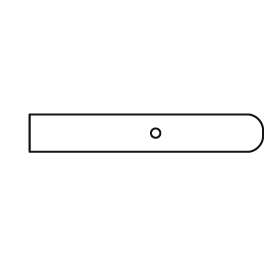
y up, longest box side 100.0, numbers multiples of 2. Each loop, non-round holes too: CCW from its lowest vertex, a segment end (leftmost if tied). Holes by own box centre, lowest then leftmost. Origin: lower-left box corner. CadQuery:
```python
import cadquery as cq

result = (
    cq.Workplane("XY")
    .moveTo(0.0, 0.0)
    .lineTo(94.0, 0.0)
    .threePointArc((98.0, 2.0), (100.0, 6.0))
    .lineTo(100.0, 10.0)
    .threePointArc((98.0, 14.0), (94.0, 16.0))
    .lineTo(0.0, 16.0)
    .close()
    .moveTo(54.0, 8.0)
    .circle(2.0)
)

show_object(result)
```